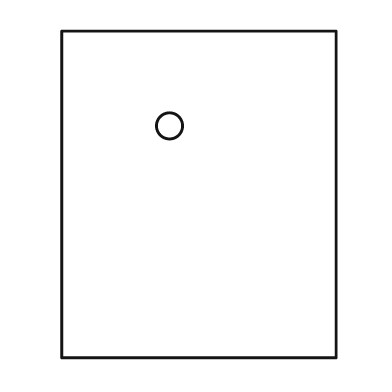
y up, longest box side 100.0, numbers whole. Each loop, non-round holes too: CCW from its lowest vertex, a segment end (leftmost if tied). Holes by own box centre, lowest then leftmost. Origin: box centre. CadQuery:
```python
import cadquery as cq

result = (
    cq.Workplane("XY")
    .moveTo(-42.0, -50.0)
    .lineTo(42.0, -50.0)
    .lineTo(42.0, 50.0)
    .lineTo(-42.0, 50.0)
    .close()
    .moveTo(-9.0, 21.0)
    .circle(4.0)
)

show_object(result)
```